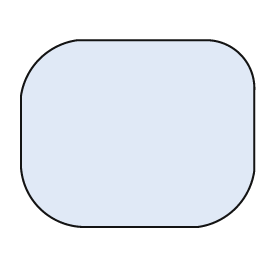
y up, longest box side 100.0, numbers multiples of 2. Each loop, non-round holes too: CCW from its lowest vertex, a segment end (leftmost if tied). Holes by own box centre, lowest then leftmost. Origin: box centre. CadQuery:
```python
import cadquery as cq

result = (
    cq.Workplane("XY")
    .moveTo(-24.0, -40.0)
    .lineTo(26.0, -40.0)
    .threePointArc((42.0, -32.0), (50.0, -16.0))
    .lineTo(50.0, 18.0)
    .threePointArc((44.0, 34.0), (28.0, 40.0))
    .lineTo(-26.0, 40.0)
    .threePointArc((-42.0, 32.0), (-50.0, 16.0))
    .lineTo(-50.0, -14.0)
    .threePointArc((-42.0, -32.0), (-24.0, -40.0))
    .close()
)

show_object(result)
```